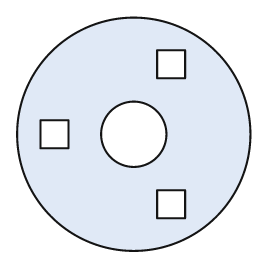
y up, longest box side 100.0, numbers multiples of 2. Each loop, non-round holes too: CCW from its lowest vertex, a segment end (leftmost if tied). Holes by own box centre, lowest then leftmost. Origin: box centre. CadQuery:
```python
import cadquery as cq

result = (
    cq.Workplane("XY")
    .moveTo(0.0, 0.0)
    .circle(50.0)
    .moveTo(10.0, -36.0)
    .lineTo(22.0, -36.0)
    .lineTo(22.0, -24.0)
    .lineTo(10.0, -24.0)
    .close()
    .moveTo(-40.0, -6.0)
    .lineTo(-28.0, -6.0)
    .lineTo(-28.0, 6.0)
    .lineTo(-40.0, 6.0)
    .close()
    .moveTo(0.0, 0.0)
    .circle(14.0)
    .moveTo(10.0, 24.0)
    .lineTo(22.0, 24.0)
    .lineTo(22.0, 36.0)
    .lineTo(10.0, 36.0)
    .close()
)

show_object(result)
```